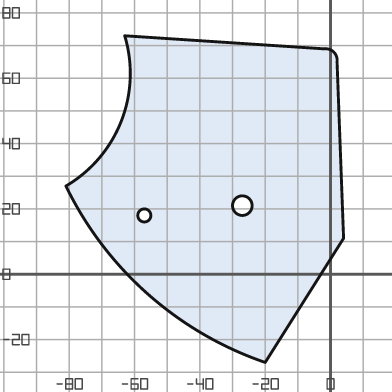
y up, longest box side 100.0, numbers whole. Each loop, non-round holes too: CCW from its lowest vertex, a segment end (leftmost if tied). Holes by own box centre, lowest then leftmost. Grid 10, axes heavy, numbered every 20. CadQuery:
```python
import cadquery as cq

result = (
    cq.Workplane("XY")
    .moveTo(-20.0, -27.0)
    .lineTo(4.0, 11.0)
    .lineTo(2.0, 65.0)
    .threePointArc((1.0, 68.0), (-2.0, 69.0))
    .lineTo(-63.0, 73.0)
    .threePointArc((-64.0, 47.0), (-81.0, 27.0))
    .threePointArc((-56.0, -6.0), (-20.0, -27.0))
    .close()
    .moveTo(-57.0, 18.0)
    .circle(2.0)
    .moveTo(-27.0, 21.0)
    .circle(3.0)
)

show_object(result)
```